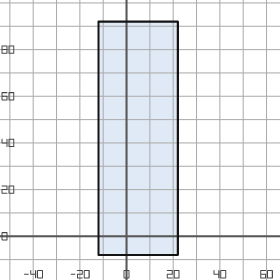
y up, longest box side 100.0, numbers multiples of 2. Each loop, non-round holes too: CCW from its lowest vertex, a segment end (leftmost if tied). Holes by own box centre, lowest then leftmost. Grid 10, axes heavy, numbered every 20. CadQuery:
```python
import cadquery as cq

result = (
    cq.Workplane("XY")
    .moveTo(-12.0, -8.0)
    .lineTo(22.0, -8.0)
    .lineTo(22.0, 92.0)
    .lineTo(-12.0, 92.0)
    .close()
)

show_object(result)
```